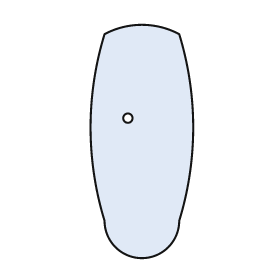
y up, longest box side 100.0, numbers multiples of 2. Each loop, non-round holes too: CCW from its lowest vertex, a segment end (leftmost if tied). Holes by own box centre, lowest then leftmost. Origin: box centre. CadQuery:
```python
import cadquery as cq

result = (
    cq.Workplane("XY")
    .moveTo(-16.0, -34.0)
    .threePointArc((0.0, -50.0), (16.0, -34.0))
    .threePointArc((22.0, 6.0), (16.0, 46.0))
    .threePointArc((0.0, 50.0), (-16.0, 46.0))
    .threePointArc((-22.0, 6.0), (-16.0, -34.0))
    .close()
    .moveTo(-6.0, 10.0)
    .circle(2.0)
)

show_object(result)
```